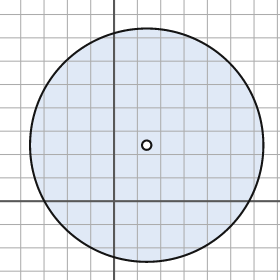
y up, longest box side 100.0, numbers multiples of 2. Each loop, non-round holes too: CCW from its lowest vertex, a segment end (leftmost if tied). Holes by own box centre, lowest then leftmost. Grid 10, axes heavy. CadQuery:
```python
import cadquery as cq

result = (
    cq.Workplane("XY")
    .moveTo(14.0, 24.0)
    .circle(50.0)
    .moveTo(14.0, 24.0)
    .circle(2.0)
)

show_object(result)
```